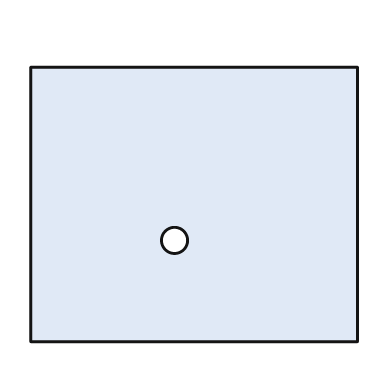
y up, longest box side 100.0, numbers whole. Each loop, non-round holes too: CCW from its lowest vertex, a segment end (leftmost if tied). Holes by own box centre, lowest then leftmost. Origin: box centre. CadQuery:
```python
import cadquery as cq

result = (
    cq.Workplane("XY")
    .moveTo(-50.0, -42.0)
    .lineTo(50.0, -42.0)
    .lineTo(50.0, 42.0)
    .lineTo(-50.0, 42.0)
    .close()
    .moveTo(-6.0, -11.0)
    .circle(4.0)
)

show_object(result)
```